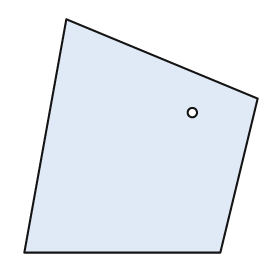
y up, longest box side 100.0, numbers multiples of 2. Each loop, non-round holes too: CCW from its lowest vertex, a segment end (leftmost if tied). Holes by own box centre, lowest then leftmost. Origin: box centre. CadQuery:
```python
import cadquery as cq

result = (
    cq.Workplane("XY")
    .moveTo(-50.0, -50.0)
    .lineTo(34.0, -50.0)
    .lineTo(50.0, 16.0)
    .lineTo(-32.0, 50.0)
    .close()
    .moveTo(22.0, 10.0)
    .circle(2.0)
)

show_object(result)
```